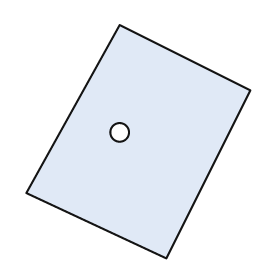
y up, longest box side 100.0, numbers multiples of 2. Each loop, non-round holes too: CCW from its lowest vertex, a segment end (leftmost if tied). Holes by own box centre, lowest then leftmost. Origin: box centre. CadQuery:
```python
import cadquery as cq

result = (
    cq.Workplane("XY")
    .moveTo(12.0, -50.0)
    .lineTo(48.0, 22.0)
    .lineTo(-8.0, 50.0)
    .lineTo(-48.0, -22.0)
    .close()
    .moveTo(-8.0, 4.0)
    .circle(4.0)
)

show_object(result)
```